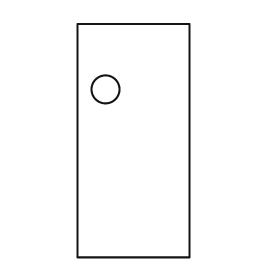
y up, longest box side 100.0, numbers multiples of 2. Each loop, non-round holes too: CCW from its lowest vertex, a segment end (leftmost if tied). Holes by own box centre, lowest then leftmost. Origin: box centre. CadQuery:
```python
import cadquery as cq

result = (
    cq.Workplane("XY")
    .moveTo(-24.0, -50.0)
    .lineTo(24.0, -50.0)
    .lineTo(24.0, 50.0)
    .lineTo(-24.0, 50.0)
    .close()
    .moveTo(-12.0, 22.0)
    .circle(6.0)
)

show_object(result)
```